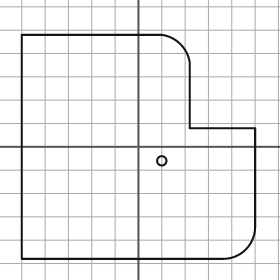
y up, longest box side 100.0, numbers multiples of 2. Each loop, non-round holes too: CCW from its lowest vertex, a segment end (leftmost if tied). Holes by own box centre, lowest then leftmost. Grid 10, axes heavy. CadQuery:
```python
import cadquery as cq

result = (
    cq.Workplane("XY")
    .moveTo(-50.0, -48.0)
    .lineTo(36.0, -48.0)
    .threePointArc((46.0, -44.0), (50.0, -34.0))
    .lineTo(50.0, 8.0)
    .lineTo(22.0, 8.0)
    .lineTo(22.0, 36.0)
    .threePointArc((18.0, 44.0), (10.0, 48.0))
    .lineTo(-50.0, 48.0)
    .close()
    .moveTo(10.0, -6.0)
    .circle(2.0)
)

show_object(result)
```